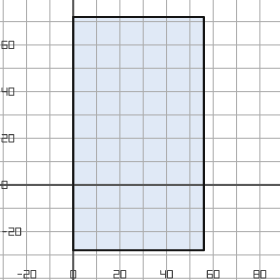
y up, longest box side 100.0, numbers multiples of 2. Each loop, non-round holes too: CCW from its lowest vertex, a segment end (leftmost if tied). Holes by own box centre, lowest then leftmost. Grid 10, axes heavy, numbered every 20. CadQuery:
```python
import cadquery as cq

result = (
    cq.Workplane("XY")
    .moveTo(0.0, -28.0)
    .lineTo(56.0, -28.0)
    .lineTo(56.0, 72.0)
    .lineTo(0.0, 72.0)
    .close()
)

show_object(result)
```